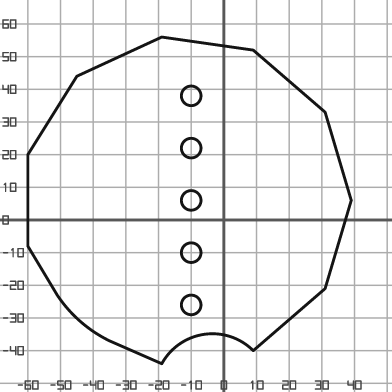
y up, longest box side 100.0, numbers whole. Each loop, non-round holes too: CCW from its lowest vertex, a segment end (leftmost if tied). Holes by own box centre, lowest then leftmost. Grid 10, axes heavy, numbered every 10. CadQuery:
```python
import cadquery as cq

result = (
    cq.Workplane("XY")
    .moveTo(-19.0, -44.0)
    .threePointArc((-6.0, -35.0), (9.0, -40.0))
    .lineTo(31.0, -21.0)
    .lineTo(39.0, 6.0)
    .lineTo(31.0, 33.0)
    .lineTo(9.0, 52.0)
    .lineTo(-19.0, 56.0)
    .lineTo(-45.0, 44.0)
    .lineTo(-60.0, 20.0)
    .lineTo(-60.0, -8.0)
    .lineTo(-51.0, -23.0)
    .threePointArc((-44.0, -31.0), (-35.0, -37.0))
    .close()
    .moveTo(-10.0, -26.0)
    .circle(3.0)
    .moveTo(-10.0, -10.0)
    .circle(3.0)
    .moveTo(-10.0, 6.0)
    .circle(3.0)
    .moveTo(-10.0, 22.0)
    .circle(3.0)
    .moveTo(-10.0, 38.0)
    .circle(3.0)
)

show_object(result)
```